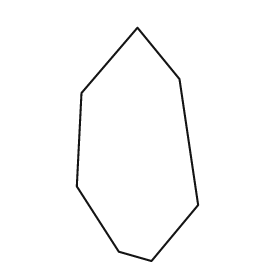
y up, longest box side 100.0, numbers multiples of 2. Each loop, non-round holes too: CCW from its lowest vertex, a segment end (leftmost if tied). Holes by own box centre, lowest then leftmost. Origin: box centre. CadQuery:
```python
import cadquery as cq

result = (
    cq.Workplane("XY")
    .moveTo(6.0, -50.0)
    .lineTo(26.0, -26.0)
    .lineTo(18.0, 28.0)
    .lineTo(0.0, 50.0)
    .lineTo(-24.0, 22.0)
    .lineTo(-26.0, -18.0)
    .lineTo(-8.0, -46.0)
    .close()
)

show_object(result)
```